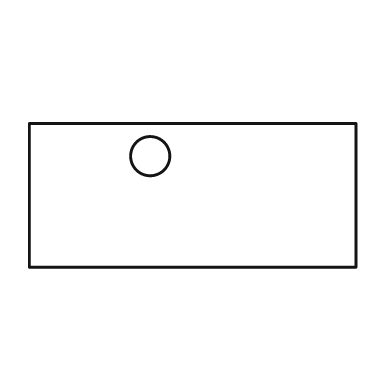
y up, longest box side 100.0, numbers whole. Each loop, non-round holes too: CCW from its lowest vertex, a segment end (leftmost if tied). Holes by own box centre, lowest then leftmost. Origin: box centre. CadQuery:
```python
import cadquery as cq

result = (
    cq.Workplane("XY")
    .moveTo(-50.0, -22.0)
    .lineTo(50.0, -22.0)
    .lineTo(50.0, 22.0)
    .lineTo(-50.0, 22.0)
    .close()
    .moveTo(-13.0, 12.0)
    .circle(6.0)
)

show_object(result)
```